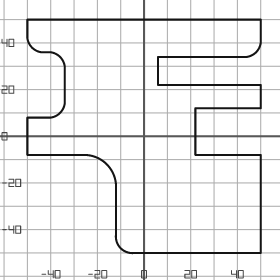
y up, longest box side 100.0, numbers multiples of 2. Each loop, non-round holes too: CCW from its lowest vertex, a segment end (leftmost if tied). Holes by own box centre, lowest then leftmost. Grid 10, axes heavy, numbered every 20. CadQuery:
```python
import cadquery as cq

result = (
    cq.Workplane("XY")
    .moveTo(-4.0, -50.0)
    .lineTo(50.0, -50.0)
    .lineTo(50.0, -8.0)
    .lineTo(22.0, -8.0)
    .lineTo(22.0, 12.0)
    .lineTo(50.0, 12.0)
    .lineTo(50.0, 22.0)
    .lineTo(6.0, 22.0)
    .lineTo(6.0, 34.0)
    .lineTo(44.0, 34.0)
    .threePointArc((48.0, 36.0), (50.0, 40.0))
    .lineTo(50.0, 50.0)
    .lineTo(-50.0, 50.0)
    .lineTo(-50.0, 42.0)
    .threePointArc((-48.0, 38.0), (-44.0, 36.0))
    .lineTo(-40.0, 36.0)
    .threePointArc((-36.0, 34.0), (-34.0, 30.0))
    .lineTo(-34.0, 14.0)
    .threePointArc((-36.0, 10.0), (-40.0, 8.0))
    .lineTo(-50.0, 8.0)
    .lineTo(-50.0, -8.0)
    .lineTo(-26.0, -8.0)
    .threePointArc((-16.0, -12.0), (-12.0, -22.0))
    .lineTo(-12.0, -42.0)
    .threePointArc((-10.0, -48.0), (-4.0, -50.0))
    .close()
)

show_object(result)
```